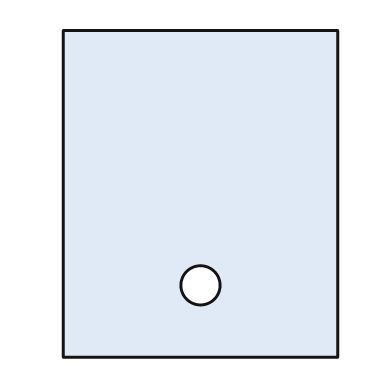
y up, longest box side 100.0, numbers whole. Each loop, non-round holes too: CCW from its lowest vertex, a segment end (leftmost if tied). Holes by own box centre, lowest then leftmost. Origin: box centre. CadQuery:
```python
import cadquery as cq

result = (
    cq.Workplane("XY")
    .moveTo(-42.0, -50.0)
    .lineTo(42.0, -50.0)
    .lineTo(42.0, 50.0)
    .lineTo(-42.0, 50.0)
    .close()
    .moveTo(0.0, -28.0)
    .circle(6.0)
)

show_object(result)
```